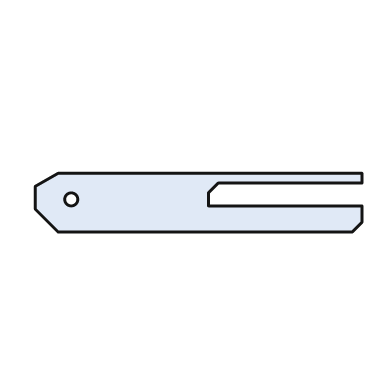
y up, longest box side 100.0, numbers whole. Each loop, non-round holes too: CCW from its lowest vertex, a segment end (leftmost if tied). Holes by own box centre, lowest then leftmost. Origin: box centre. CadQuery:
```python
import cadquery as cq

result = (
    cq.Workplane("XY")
    .moveTo(-43.0, -9.0)
    .lineTo(47.0, -9.0)
    .lineTo(50.0, -6.0)
    .lineTo(50.0, -1.0)
    .lineTo(3.0, -1.0)
    .lineTo(3.0, 3.0)
    .lineTo(6.0, 6.0)
    .lineTo(50.0, 6.0)
    .lineTo(50.0, 9.0)
    .lineTo(-43.0, 9.0)
    .lineTo(-50.0, 5.0)
    .lineTo(-50.0, -2.0)
    .close()
    .moveTo(-39.0, 1.0)
    .circle(2.0)
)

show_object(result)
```